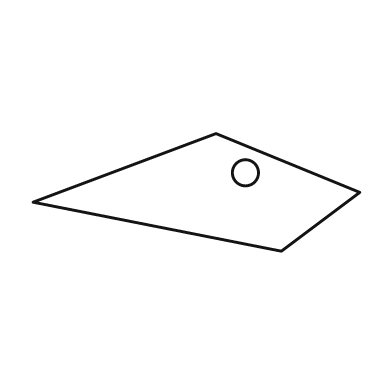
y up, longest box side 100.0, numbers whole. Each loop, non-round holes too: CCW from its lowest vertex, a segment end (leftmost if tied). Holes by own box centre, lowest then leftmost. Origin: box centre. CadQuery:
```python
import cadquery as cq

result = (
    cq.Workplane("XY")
    .moveTo(26.0, -18.0)
    .lineTo(50.0, 0.0)
    .lineTo(6.0, 18.0)
    .lineTo(-50.0, -3.0)
    .close()
    .moveTo(15.0, 6.0)
    .circle(4.0)
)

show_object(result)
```